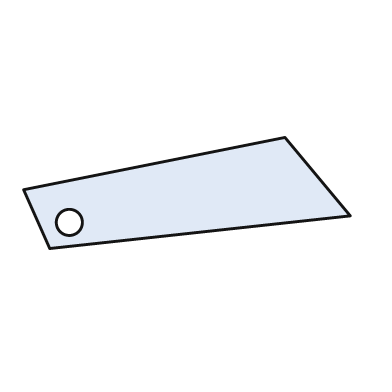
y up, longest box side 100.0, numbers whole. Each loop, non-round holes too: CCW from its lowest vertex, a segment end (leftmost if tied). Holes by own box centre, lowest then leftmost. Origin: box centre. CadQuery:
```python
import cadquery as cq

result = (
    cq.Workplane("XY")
    .moveTo(-42.0, -17.0)
    .lineTo(50.0, -7.0)
    .lineTo(30.0, 17.0)
    .lineTo(-50.0, 1.0)
    .close()
    .moveTo(-36.0, -9.0)
    .circle(4.0)
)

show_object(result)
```